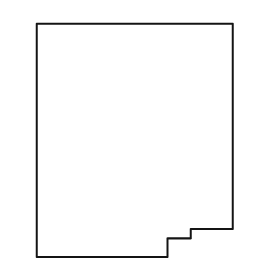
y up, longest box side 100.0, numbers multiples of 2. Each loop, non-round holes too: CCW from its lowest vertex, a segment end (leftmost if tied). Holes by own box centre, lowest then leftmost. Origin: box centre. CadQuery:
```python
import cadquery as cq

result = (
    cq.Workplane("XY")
    .moveTo(-42.0, -50.0)
    .lineTo(14.0, -50.0)
    .lineTo(14.0, -42.0)
    .lineTo(24.0, -42.0)
    .lineTo(24.0, -38.0)
    .lineTo(42.0, -38.0)
    .lineTo(42.0, 50.0)
    .lineTo(-42.0, 50.0)
    .close()
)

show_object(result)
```